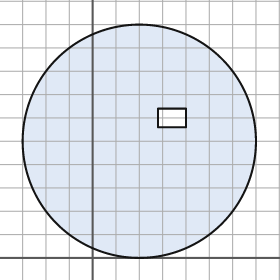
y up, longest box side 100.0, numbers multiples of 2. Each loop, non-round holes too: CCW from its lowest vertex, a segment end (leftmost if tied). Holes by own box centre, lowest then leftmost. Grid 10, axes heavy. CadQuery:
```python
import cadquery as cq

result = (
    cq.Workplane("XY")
    .moveTo(20.0, 50.0)
    .circle(50.0)
    .moveTo(28.0, 56.0)
    .lineTo(40.0, 56.0)
    .lineTo(40.0, 64.0)
    .lineTo(28.0, 64.0)
    .close()
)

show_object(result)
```